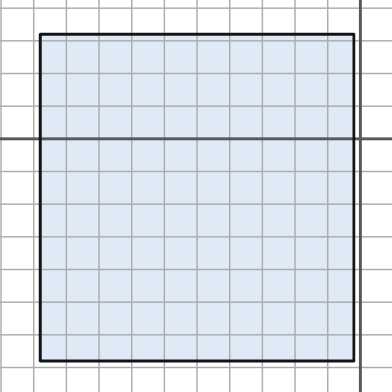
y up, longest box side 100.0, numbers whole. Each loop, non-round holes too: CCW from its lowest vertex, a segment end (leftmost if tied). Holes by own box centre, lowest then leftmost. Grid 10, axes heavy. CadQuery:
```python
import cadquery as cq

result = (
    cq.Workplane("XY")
    .moveTo(-98.0, -68.0)
    .lineTo(-2.0, -68.0)
    .lineTo(-2.0, 32.0)
    .lineTo(-98.0, 32.0)
    .close()
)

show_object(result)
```